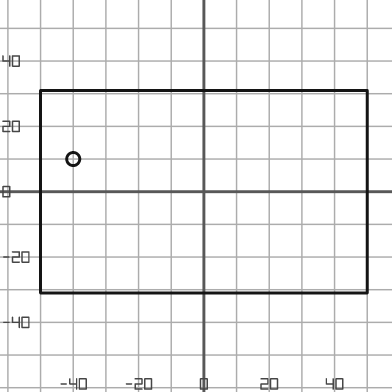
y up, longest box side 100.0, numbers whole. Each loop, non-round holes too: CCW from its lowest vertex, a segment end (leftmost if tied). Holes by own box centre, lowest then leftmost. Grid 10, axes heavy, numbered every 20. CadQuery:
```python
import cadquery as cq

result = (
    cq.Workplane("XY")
    .moveTo(-50.0, -31.0)
    .lineTo(50.0, -31.0)
    .lineTo(50.0, 31.0)
    .lineTo(-50.0, 31.0)
    .close()
    .moveTo(-40.0, 10.0)
    .circle(2.0)
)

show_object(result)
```